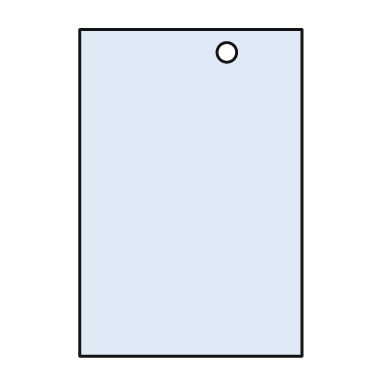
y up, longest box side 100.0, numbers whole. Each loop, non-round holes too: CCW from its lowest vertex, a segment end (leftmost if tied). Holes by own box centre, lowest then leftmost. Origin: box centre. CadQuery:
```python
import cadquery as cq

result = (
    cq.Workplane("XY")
    .moveTo(-34.0, -50.0)
    .lineTo(34.0, -50.0)
    .lineTo(34.0, 50.0)
    .lineTo(-34.0, 50.0)
    .close()
    .moveTo(11.0, 43.0)
    .circle(3.0)
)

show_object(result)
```